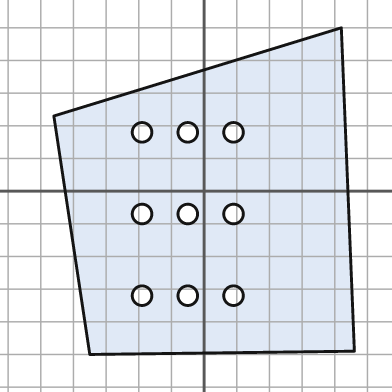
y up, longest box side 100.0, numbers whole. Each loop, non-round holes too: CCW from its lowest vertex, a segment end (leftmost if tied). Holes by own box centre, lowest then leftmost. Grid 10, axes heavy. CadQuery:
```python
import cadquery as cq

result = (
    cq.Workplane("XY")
    .moveTo(-35.0, -50.0)
    .lineTo(46.0, -49.0)
    .lineTo(42.0, 50.0)
    .lineTo(-46.0, 23.0)
    .close()
    .moveTo(-19.0, -32.0)
    .circle(3.0)
    .moveTo(-5.0, -32.0)
    .circle(3.0)
    .moveTo(9.0, -32.0)
    .circle(3.0)
    .moveTo(-19.0, -7.0)
    .circle(3.0)
    .moveTo(-5.0, -7.0)
    .circle(3.0)
    .moveTo(9.0, -7.0)
    .circle(3.0)
    .moveTo(-19.0, 18.0)
    .circle(3.0)
    .moveTo(-5.0, 18.0)
    .circle(3.0)
    .moveTo(9.0, 18.0)
    .circle(3.0)
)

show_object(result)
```